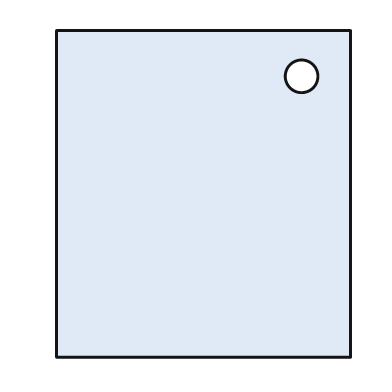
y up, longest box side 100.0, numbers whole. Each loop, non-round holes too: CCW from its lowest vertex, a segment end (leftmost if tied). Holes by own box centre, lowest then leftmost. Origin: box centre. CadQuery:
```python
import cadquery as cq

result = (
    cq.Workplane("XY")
    .moveTo(-45.0, -50.0)
    .lineTo(45.0, -50.0)
    .lineTo(45.0, 50.0)
    .lineTo(-45.0, 50.0)
    .close()
    .moveTo(30.0, 36.0)
    .circle(5.0)
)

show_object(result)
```